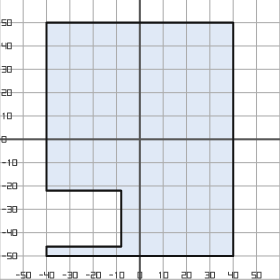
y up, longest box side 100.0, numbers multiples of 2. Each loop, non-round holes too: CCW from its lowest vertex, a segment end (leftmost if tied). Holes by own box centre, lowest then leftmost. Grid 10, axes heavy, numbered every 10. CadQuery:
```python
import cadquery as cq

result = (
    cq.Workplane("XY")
    .moveTo(-40.0, -50.0)
    .lineTo(40.0, -50.0)
    .lineTo(40.0, 50.0)
    .lineTo(-40.0, 50.0)
    .lineTo(-40.0, -22.0)
    .lineTo(-8.0, -22.0)
    .lineTo(-8.0, -46.0)
    .lineTo(-40.0, -46.0)
    .close()
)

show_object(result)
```